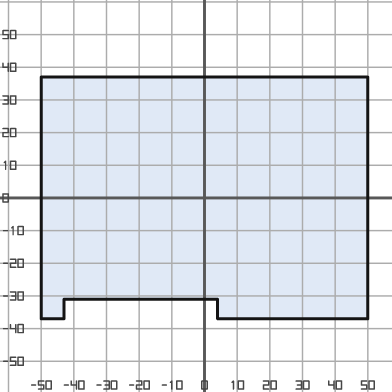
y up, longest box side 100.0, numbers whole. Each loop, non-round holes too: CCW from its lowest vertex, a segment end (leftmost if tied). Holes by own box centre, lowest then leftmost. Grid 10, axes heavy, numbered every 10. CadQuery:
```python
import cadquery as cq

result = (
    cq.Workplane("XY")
    .moveTo(-50.0, -37.0)
    .lineTo(-43.0, -37.0)
    .lineTo(-43.0, -31.0)
    .lineTo(4.0, -31.0)
    .lineTo(4.0, -37.0)
    .lineTo(50.0, -37.0)
    .lineTo(50.0, 37.0)
    .lineTo(-50.0, 37.0)
    .close()
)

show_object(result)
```